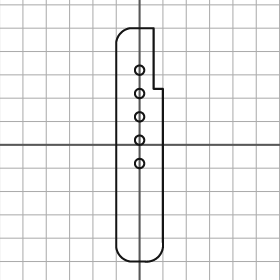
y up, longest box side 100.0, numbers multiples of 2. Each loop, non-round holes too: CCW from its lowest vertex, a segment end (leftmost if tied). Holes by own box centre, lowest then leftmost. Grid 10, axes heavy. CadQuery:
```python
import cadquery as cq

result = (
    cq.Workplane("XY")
    .moveTo(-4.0, -50.0)
    .lineTo(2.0, -50.0)
    .threePointArc((8.0, -48.0), (10.0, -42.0))
    .lineTo(10.0, 24.0)
    .lineTo(6.0, 24.0)
    .lineTo(6.0, 50.0)
    .lineTo(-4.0, 50.0)
    .threePointArc((-8.0, 48.0), (-10.0, 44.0))
    .lineTo(-10.0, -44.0)
    .threePointArc((-8.0, -48.0), (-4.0, -50.0))
    .close()
    .moveTo(0.0, -8.0)
    .circle(2.0)
    .moveTo(0.0, 2.0)
    .circle(2.0)
    .moveTo(0.0, 12.0)
    .circle(2.0)
    .moveTo(0.0, 22.0)
    .circle(2.0)
    .moveTo(0.0, 32.0)
    .circle(2.0)
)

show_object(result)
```